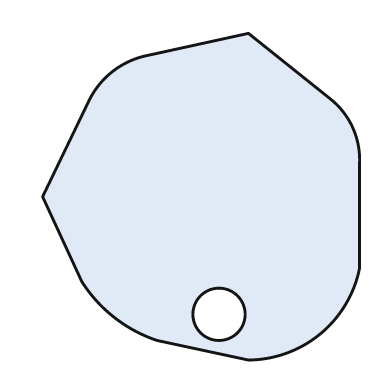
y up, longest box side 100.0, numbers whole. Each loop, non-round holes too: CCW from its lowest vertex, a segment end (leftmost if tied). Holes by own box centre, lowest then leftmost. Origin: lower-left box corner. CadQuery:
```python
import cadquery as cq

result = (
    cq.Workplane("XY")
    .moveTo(63.0, 0.0)
    .threePointArc((85.0, 8.0), (97.0, 28.0))
    .lineTo(97.0, 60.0)
    .threePointArc((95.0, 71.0), (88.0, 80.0))
    .lineTo(63.0, 100.0)
    .lineTo(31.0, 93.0)
    .threePointArc((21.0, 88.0), (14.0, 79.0))
    .lineTo(0.0, 50.0)
    .lineTo(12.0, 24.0)
    .threePointArc((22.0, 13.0), (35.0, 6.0))
    .close()
    .moveTo(54.0, 14.0)
    .circle(8.0)
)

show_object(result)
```